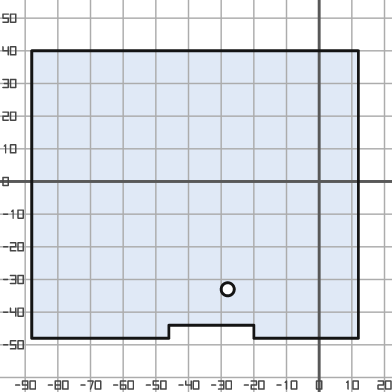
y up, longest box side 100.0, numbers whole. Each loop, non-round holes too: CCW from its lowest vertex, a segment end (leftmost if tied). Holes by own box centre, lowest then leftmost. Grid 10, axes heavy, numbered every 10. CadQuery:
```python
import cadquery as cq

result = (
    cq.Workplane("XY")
    .moveTo(-88.0, -48.0)
    .lineTo(-46.0, -48.0)
    .lineTo(-46.0, -44.0)
    .lineTo(-20.0, -44.0)
    .lineTo(-20.0, -48.0)
    .lineTo(12.0, -48.0)
    .lineTo(12.0, 40.0)
    .lineTo(-88.0, 40.0)
    .close()
    .moveTo(-28.0, -33.0)
    .circle(2.0)
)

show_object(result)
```